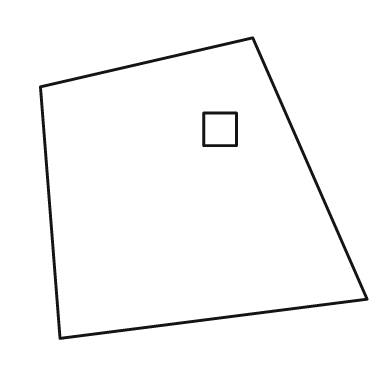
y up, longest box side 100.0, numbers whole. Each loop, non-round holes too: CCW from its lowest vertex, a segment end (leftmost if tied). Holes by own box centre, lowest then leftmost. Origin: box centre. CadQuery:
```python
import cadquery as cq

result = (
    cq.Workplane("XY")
    .moveTo(-44.0, -46.0)
    .lineTo(50.0, -34.0)
    .lineTo(15.0, 46.0)
    .lineTo(-50.0, 31.0)
    .close()
    .moveTo(0.0, 13.0)
    .lineTo(10.0, 13.0)
    .lineTo(10.0, 23.0)
    .lineTo(0.0, 23.0)
    .close()
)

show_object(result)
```